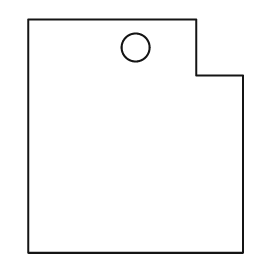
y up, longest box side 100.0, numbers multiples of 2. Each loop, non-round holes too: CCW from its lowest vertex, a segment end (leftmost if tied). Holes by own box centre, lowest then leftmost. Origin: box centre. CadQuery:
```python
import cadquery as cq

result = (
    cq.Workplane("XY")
    .moveTo(-46.0, -50.0)
    .lineTo(46.0, -50.0)
    .lineTo(46.0, 26.0)
    .lineTo(26.0, 26.0)
    .lineTo(26.0, 50.0)
    .lineTo(-46.0, 50.0)
    .close()
    .moveTo(0.0, 38.0)
    .circle(6.0)
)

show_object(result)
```